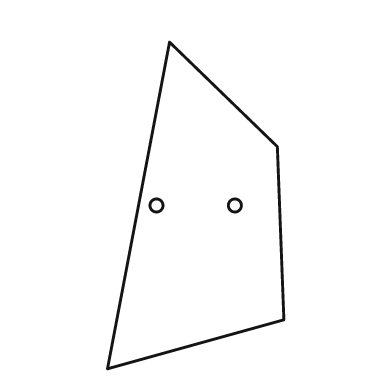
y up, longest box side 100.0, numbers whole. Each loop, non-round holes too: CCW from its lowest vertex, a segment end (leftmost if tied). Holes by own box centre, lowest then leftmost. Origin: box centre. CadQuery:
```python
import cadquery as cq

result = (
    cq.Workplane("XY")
    .moveTo(-27.0, -50.0)
    .lineTo(27.0, -35.0)
    .lineTo(25.0, 18.0)
    .lineTo(-8.0, 50.0)
    .close()
    .moveTo(-12.0, 0.0)
    .circle(2.0)
    .moveTo(12.0, 0.0)
    .circle(2.0)
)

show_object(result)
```